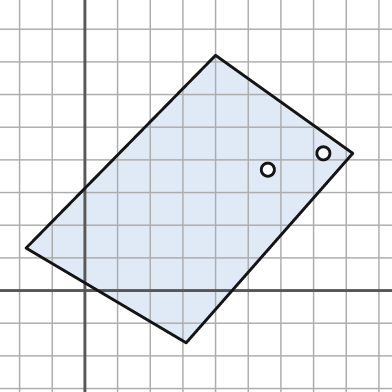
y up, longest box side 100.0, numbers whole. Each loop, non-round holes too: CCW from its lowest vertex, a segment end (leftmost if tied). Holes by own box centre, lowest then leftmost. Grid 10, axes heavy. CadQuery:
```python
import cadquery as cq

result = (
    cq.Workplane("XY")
    .moveTo(31.0, -16.0)
    .lineTo(82.0, 42.0)
    .lineTo(40.0, 72.0)
    .lineTo(-18.0, 13.0)
    .close()
    .moveTo(56.0, 37.0)
    .circle(2.0)
    .moveTo(73.0, 42.0)
    .circle(2.0)
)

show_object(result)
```